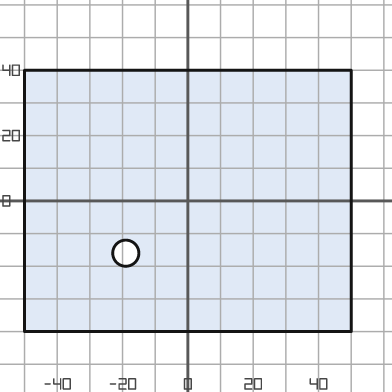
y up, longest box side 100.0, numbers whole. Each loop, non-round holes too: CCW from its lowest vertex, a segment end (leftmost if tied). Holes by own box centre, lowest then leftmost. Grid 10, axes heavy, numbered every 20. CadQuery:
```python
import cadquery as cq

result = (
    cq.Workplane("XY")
    .moveTo(-50.0, -40.0)
    .lineTo(50.0, -40.0)
    .lineTo(50.0, 40.0)
    .lineTo(-50.0, 40.0)
    .close()
    .moveTo(-19.0, -16.0)
    .circle(4.0)
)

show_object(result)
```